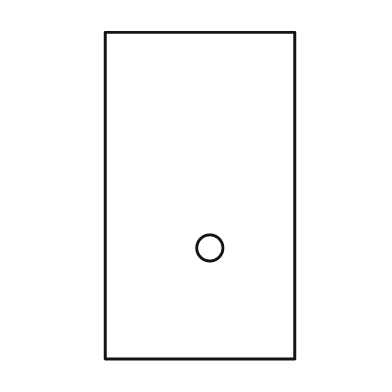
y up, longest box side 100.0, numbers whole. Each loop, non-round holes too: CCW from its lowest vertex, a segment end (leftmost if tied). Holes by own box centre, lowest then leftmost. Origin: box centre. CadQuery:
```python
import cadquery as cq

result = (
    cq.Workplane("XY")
    .moveTo(-29.0, -50.0)
    .lineTo(29.0, -50.0)
    .lineTo(29.0, 50.0)
    .lineTo(-29.0, 50.0)
    .close()
    .moveTo(3.0, -16.0)
    .circle(4.0)
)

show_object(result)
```